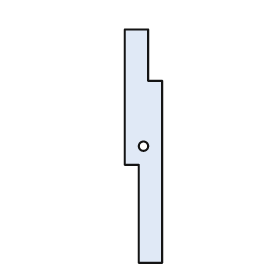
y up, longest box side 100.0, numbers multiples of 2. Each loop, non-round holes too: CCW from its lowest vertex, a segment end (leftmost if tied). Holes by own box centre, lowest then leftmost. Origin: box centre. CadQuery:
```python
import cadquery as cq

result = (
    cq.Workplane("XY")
    .moveTo(-2.0, -50.0)
    .lineTo(8.0, -50.0)
    .lineTo(8.0, 28.0)
    .lineTo(2.0, 28.0)
    .lineTo(2.0, 50.0)
    .lineTo(-8.0, 50.0)
    .lineTo(-8.0, -8.0)
    .lineTo(-2.0, -8.0)
    .close()
    .moveTo(0.0, 0.0)
    .circle(2.0)
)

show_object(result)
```